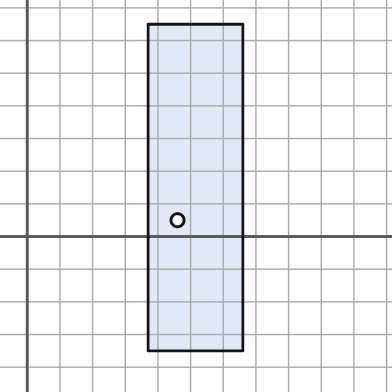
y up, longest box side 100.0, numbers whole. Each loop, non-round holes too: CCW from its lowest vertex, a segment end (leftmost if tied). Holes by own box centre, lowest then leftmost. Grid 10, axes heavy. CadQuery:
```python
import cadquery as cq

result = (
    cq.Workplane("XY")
    .moveTo(37.0, -35.0)
    .lineTo(66.0, -35.0)
    .lineTo(66.0, 65.0)
    .lineTo(37.0, 65.0)
    .close()
    .moveTo(46.0, 5.0)
    .circle(2.0)
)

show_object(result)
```